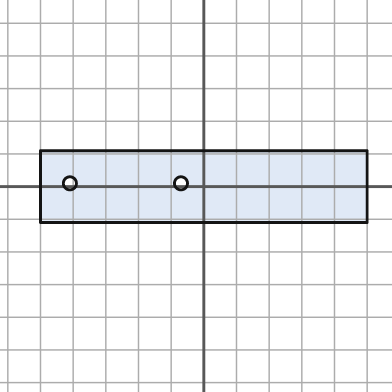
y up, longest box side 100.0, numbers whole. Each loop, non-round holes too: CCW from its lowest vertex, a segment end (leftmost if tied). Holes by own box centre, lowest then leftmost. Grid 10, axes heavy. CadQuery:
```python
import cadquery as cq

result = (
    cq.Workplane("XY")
    .moveTo(-50.0, -11.0)
    .lineTo(50.0, -11.0)
    .lineTo(50.0, 11.0)
    .lineTo(-50.0, 11.0)
    .close()
    .moveTo(-41.0, 1.0)
    .circle(2.0)
    .moveTo(-7.0, 1.0)
    .circle(2.0)
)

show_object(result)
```